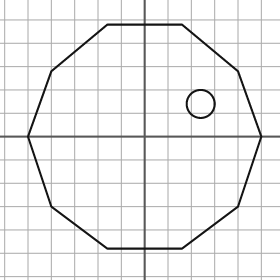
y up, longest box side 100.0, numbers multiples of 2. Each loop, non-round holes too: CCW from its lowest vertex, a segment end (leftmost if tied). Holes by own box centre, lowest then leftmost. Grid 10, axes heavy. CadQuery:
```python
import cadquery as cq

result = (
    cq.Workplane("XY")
    .moveTo(-16.0, -48.0)
    .lineTo(16.0, -48.0)
    .lineTo(40.0, -30.0)
    .lineTo(50.0, 0.0)
    .lineTo(40.0, 28.0)
    .lineTo(16.0, 48.0)
    .lineTo(-16.0, 48.0)
    .lineTo(-40.0, 28.0)
    .lineTo(-50.0, 0.0)
    .lineTo(-40.0, -30.0)
    .close()
    .moveTo(24.0, 14.0)
    .circle(6.0)
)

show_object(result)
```